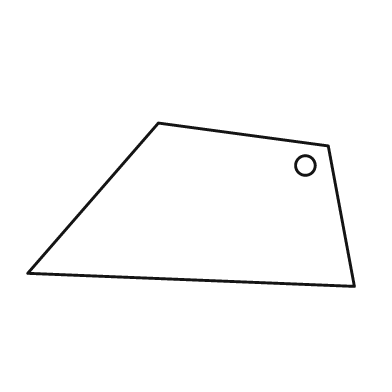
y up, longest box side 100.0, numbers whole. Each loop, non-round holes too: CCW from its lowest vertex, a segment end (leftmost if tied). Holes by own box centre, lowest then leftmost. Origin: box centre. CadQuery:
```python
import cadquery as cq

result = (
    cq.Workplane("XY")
    .moveTo(50.0, -25.0)
    .lineTo(42.0, 18.0)
    .lineTo(-10.0, 25.0)
    .lineTo(-50.0, -21.0)
    .close()
    .moveTo(35.0, 12.0)
    .circle(3.0)
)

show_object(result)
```